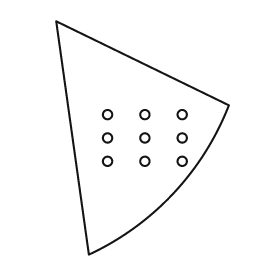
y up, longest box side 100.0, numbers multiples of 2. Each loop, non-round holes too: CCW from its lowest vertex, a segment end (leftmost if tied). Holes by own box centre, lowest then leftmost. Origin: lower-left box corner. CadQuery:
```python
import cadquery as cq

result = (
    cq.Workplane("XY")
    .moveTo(14.0, 0.0)
    .threePointArc((50.0, 26.0), (74.0, 64.0))
    .lineTo(0.0, 100.0)
    .close()
    .moveTo(22.0, 40.0)
    .circle(2.0)
    .moveTo(38.0, 40.0)
    .circle(2.0)
    .moveTo(54.0, 40.0)
    .circle(2.0)
    .moveTo(22.0, 50.0)
    .circle(2.0)
    .moveTo(38.0, 50.0)
    .circle(2.0)
    .moveTo(54.0, 50.0)
    .circle(2.0)
    .moveTo(22.0, 60.0)
    .circle(2.0)
    .moveTo(38.0, 60.0)
    .circle(2.0)
    .moveTo(54.0, 60.0)
    .circle(2.0)
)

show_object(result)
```